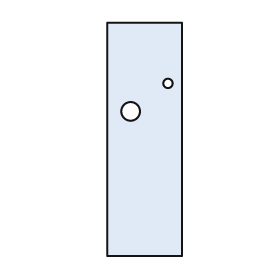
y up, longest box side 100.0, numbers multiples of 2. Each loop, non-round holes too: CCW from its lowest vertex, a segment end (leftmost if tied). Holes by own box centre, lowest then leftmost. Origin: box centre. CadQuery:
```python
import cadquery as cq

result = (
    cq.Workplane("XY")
    .moveTo(-16.0, -50.0)
    .lineTo(16.0, -50.0)
    .lineTo(16.0, 50.0)
    .lineTo(-16.0, 50.0)
    .close()
    .moveTo(-6.0, 12.0)
    .circle(4.0)
    .moveTo(10.0, 24.0)
    .circle(2.0)
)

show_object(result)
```